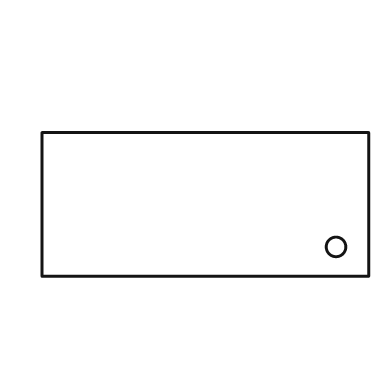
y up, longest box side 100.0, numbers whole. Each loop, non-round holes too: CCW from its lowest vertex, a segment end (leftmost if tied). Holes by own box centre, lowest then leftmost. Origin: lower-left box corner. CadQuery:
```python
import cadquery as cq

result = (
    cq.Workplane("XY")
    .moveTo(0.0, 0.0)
    .lineTo(100.0, 0.0)
    .lineTo(100.0, 44.0)
    .lineTo(0.0, 44.0)
    .close()
    .moveTo(90.0, 9.0)
    .circle(3.0)
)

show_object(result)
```